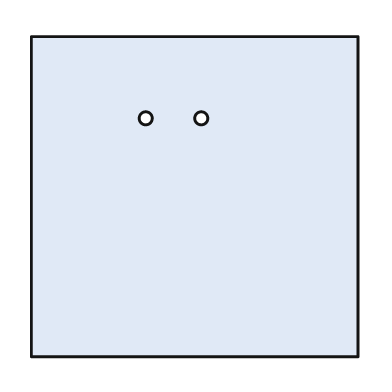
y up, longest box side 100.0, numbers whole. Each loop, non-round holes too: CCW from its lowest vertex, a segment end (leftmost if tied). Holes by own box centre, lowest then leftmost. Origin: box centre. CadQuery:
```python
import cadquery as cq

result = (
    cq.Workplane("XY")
    .moveTo(-50.0, -49.0)
    .lineTo(50.0, -49.0)
    .lineTo(50.0, 49.0)
    .lineTo(-50.0, 49.0)
    .close()
    .moveTo(-15.0, 24.0)
    .circle(2.0)
    .moveTo(2.0, 24.0)
    .circle(2.0)
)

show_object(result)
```